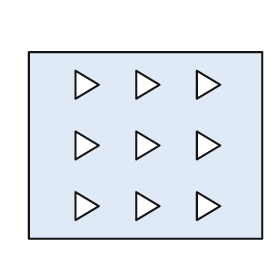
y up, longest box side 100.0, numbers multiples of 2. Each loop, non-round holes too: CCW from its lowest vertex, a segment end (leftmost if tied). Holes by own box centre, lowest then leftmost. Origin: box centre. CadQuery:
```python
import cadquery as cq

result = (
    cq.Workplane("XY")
    .moveTo(-50.0, -40.0)
    .lineTo(50.0, -40.0)
    .lineTo(50.0, 40.0)
    .lineTo(-50.0, 40.0)
    .close()
    .moveTo(-30.0, -32.0)
    .lineTo(-20.0, -26.0)
    .lineTo(-30.0, -20.0)
    .close()
    .moveTo(-4.0, -32.0)
    .lineTo(6.0, -26.0)
    .lineTo(-4.0, -20.0)
    .close()
    .moveTo(22.0, -32.0)
    .lineTo(32.0, -26.0)
    .lineTo(22.0, -20.0)
    .close()
    .moveTo(-30.0, -6.0)
    .lineTo(-20.0, 0.0)
    .lineTo(-30.0, 6.0)
    .close()
    .moveTo(-4.0, -6.0)
    .lineTo(6.0, 0.0)
    .lineTo(-4.0, 6.0)
    .close()
    .moveTo(22.0, -6.0)
    .lineTo(32.0, 0.0)
    .lineTo(22.0, 6.0)
    .close()
    .moveTo(-30.0, 20.0)
    .lineTo(-20.0, 26.0)
    .lineTo(-30.0, 32.0)
    .close()
    .moveTo(-4.0, 20.0)
    .lineTo(6.0, 26.0)
    .lineTo(-4.0, 32.0)
    .close()
    .moveTo(22.0, 20.0)
    .lineTo(32.0, 26.0)
    .lineTo(22.0, 32.0)
    .close()
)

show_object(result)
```